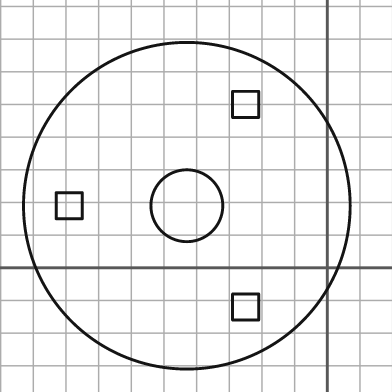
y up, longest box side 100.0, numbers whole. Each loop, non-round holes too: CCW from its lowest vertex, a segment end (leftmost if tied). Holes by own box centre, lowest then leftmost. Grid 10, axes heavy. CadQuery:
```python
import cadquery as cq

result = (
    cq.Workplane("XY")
    .moveTo(-43.0, 19.0)
    .circle(50.0)
    .moveTo(-29.0, -16.0)
    .lineTo(-21.0, -16.0)
    .lineTo(-21.0, -8.0)
    .lineTo(-29.0, -8.0)
    .close()
    .moveTo(-83.0, 15.0)
    .lineTo(-75.0, 15.0)
    .lineTo(-75.0, 23.0)
    .lineTo(-83.0, 23.0)
    .close()
    .moveTo(-43.0, 19.0)
    .circle(11.0)
    .moveTo(-29.0, 46.0)
    .lineTo(-21.0, 46.0)
    .lineTo(-21.0, 54.0)
    .lineTo(-29.0, 54.0)
    .close()
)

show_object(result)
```